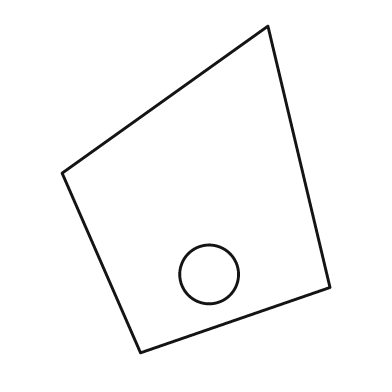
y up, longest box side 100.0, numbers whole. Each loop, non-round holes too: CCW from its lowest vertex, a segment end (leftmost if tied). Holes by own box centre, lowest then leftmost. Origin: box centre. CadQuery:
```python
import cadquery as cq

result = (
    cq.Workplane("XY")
    .moveTo(-17.0, -50.0)
    .lineTo(41.0, -30.0)
    .lineTo(22.0, 50.0)
    .lineTo(-41.0, 5.0)
    .close()
    .moveTo(4.0, -26.0)
    .circle(9.0)
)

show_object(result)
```